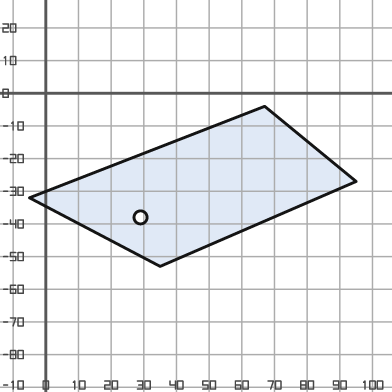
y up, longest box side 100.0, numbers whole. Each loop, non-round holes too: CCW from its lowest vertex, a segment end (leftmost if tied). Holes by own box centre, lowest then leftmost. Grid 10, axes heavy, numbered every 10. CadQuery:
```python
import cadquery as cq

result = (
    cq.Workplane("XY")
    .moveTo(35.0, -53.0)
    .lineTo(95.0, -27.0)
    .lineTo(67.0, -4.0)
    .lineTo(-5.0, -32.0)
    .close()
    .moveTo(29.0, -38.0)
    .circle(2.0)
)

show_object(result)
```